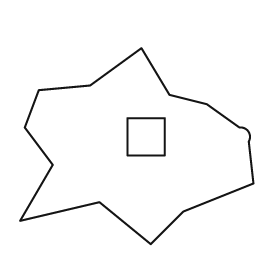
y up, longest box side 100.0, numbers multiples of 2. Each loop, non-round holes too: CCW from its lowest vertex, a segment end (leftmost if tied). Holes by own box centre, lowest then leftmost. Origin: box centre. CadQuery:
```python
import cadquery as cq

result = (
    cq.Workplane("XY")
    .moveTo(6.0, -42.0)
    .lineTo(20.0, -28.0)
    .lineTo(50.0, -16.0)
    .lineTo(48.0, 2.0)
    .threePointArc((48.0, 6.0), (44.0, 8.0))
    .lineTo(30.0, 18.0)
    .lineTo(14.0, 22.0)
    .lineTo(2.0, 42.0)
    .lineTo(-20.0, 26.0)
    .lineTo(-42.0, 24.0)
    .lineTo(-48.0, 8.0)
    .lineTo(-36.0, -8.0)
    .lineTo(-50.0, -32.0)
    .lineTo(-16.0, -24.0)
    .close()
    .moveTo(-4.0, -4.0)
    .lineTo(12.0, -4.0)
    .lineTo(12.0, 12.0)
    .lineTo(-4.0, 12.0)
    .close()
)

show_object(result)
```